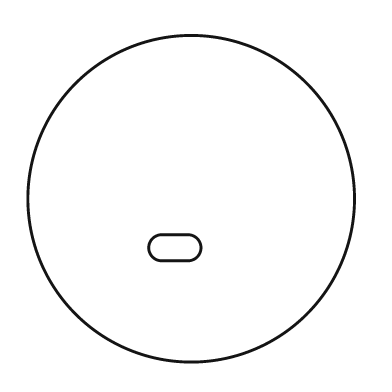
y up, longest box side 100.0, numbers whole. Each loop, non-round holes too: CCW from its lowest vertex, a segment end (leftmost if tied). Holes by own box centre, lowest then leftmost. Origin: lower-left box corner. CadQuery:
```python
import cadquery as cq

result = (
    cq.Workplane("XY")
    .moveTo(50.0, 50.0)
    .circle(50.0)
    .moveTo(41.0, 31.0)
    .lineTo(49.0, 31.0)
    .threePointArc((53.0, 35.0), (49.0, 39.0))
    .lineTo(41.0, 39.0)
    .threePointArc((37.0, 35.0), (41.0, 31.0))
    .close()
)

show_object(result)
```